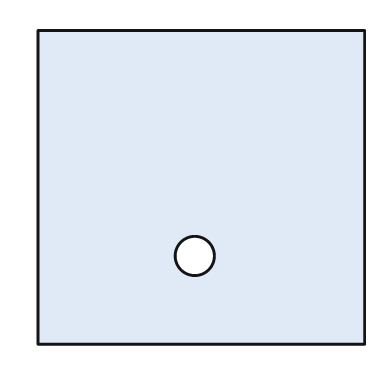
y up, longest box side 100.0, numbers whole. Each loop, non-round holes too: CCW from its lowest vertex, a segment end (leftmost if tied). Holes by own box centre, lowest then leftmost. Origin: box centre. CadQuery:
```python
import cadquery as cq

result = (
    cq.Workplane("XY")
    .moveTo(-50.0, -48.0)
    .lineTo(50.0, -48.0)
    .lineTo(50.0, 48.0)
    .lineTo(-50.0, 48.0)
    .close()
    .moveTo(-2.0, -21.0)
    .circle(6.0)
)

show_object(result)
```